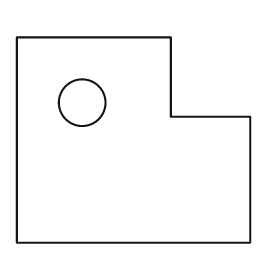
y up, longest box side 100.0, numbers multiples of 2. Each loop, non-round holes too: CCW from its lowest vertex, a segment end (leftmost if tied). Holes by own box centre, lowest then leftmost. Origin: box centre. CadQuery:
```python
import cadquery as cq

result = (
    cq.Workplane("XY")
    .moveTo(-50.0, -44.0)
    .lineTo(50.0, -44.0)
    .lineTo(50.0, 10.0)
    .lineTo(16.0, 10.0)
    .lineTo(16.0, 44.0)
    .lineTo(-50.0, 44.0)
    .close()
    .moveTo(-22.0, 16.0)
    .circle(10.0)
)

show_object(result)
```